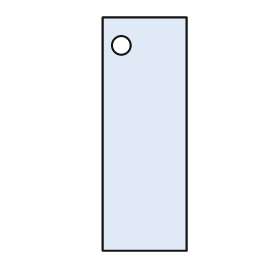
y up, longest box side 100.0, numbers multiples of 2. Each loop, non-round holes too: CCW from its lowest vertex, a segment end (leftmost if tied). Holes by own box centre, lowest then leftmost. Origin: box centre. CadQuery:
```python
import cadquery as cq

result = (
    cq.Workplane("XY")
    .moveTo(-18.0, -50.0)
    .lineTo(18.0, -50.0)
    .lineTo(18.0, 50.0)
    .lineTo(-18.0, 50.0)
    .close()
    .moveTo(-10.0, 38.0)
    .circle(4.0)
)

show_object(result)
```